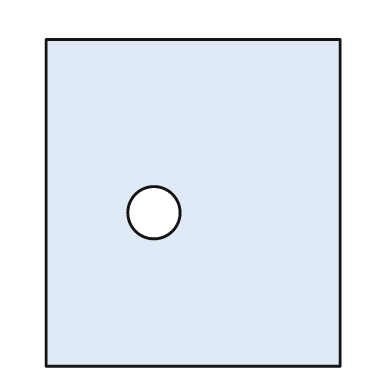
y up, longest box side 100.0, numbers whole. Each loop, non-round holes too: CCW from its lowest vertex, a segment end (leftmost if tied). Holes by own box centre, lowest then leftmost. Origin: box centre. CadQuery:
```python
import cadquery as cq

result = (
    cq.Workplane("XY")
    .moveTo(-45.0, -50.0)
    .lineTo(45.0, -50.0)
    .lineTo(45.0, 50.0)
    .lineTo(-45.0, 50.0)
    .close()
    .moveTo(-12.0, -3.0)
    .circle(8.0)
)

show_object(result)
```